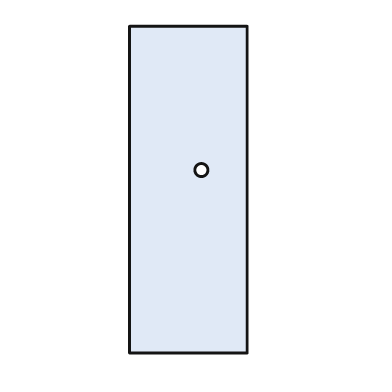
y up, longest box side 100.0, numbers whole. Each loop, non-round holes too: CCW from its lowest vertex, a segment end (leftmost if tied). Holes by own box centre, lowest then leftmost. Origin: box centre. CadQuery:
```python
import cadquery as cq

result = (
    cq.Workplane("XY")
    .moveTo(-18.0, -50.0)
    .lineTo(18.0, -50.0)
    .lineTo(18.0, 50.0)
    .lineTo(-18.0, 50.0)
    .close()
    .moveTo(4.0, 6.0)
    .circle(2.0)
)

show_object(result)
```